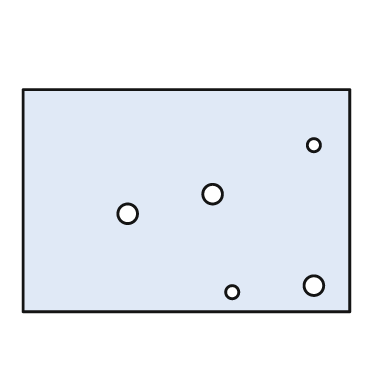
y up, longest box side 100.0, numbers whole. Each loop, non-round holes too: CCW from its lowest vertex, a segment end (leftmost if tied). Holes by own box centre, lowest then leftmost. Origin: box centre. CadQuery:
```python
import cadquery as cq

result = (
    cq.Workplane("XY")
    .moveTo(-50.0, -34.0)
    .lineTo(50.0, -34.0)
    .lineTo(50.0, 34.0)
    .lineTo(-50.0, 34.0)
    .close()
    .moveTo(14.0, -28.0)
    .circle(2.0)
    .moveTo(39.0, -26.0)
    .circle(3.0)
    .moveTo(-18.0, -4.0)
    .circle(3.0)
    .moveTo(8.0, 2.0)
    .circle(3.0)
    .moveTo(39.0, 17.0)
    .circle(2.0)
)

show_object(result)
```